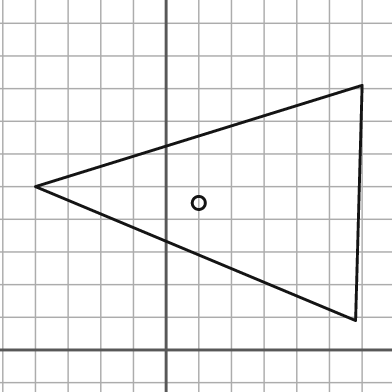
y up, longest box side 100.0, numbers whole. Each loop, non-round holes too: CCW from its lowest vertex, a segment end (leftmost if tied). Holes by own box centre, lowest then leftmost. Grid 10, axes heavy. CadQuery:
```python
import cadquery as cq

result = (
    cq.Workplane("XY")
    .moveTo(58.0, 9.0)
    .lineTo(60.0, 81.0)
    .lineTo(-40.0, 50.0)
    .close()
    .moveTo(10.0, 45.0)
    .circle(2.0)
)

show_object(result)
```